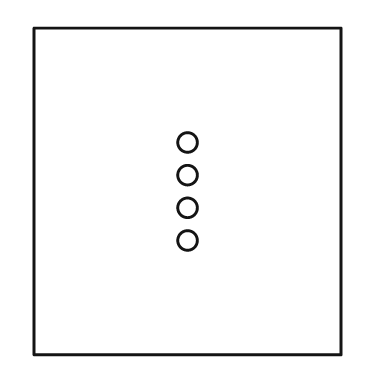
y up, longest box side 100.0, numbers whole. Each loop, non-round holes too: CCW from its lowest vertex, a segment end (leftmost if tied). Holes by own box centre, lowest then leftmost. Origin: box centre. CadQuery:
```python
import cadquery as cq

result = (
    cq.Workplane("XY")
    .moveTo(-47.0, -50.0)
    .lineTo(47.0, -50.0)
    .lineTo(47.0, 50.0)
    .lineTo(-47.0, 50.0)
    .close()
    .moveTo(0.0, -15.0)
    .circle(3.0)
    .moveTo(0.0, -5.0)
    .circle(3.0)
    .moveTo(0.0, 5.0)
    .circle(3.0)
    .moveTo(0.0, 15.0)
    .circle(3.0)
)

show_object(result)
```